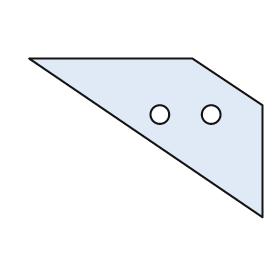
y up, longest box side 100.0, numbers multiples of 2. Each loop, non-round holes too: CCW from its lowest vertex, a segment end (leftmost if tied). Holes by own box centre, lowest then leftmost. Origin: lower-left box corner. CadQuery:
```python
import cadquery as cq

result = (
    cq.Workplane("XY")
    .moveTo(100.0, 0.0)
    .lineTo(100.0, 48.0)
    .lineTo(70.0, 68.0)
    .lineTo(0.0, 68.0)
    .close()
    .moveTo(56.0, 44.0)
    .circle(4.0)
    .moveTo(78.0, 44.0)
    .circle(4.0)
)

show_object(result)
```